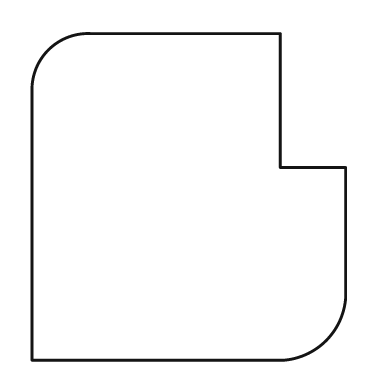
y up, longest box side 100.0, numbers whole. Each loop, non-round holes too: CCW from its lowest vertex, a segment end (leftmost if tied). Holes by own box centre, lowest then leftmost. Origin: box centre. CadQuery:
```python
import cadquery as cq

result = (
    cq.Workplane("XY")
    .moveTo(-48.0, -50.0)
    .lineTo(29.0, -50.0)
    .threePointArc((42.0, -44.0), (48.0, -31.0))
    .lineTo(48.0, 9.0)
    .lineTo(28.0, 9.0)
    .lineTo(28.0, 50.0)
    .lineTo(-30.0, 50.0)
    .threePointArc((-43.0, 45.0), (-48.0, 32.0))
    .close()
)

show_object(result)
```